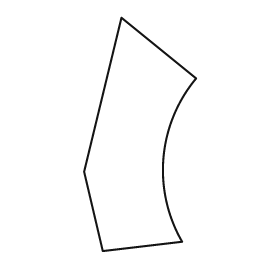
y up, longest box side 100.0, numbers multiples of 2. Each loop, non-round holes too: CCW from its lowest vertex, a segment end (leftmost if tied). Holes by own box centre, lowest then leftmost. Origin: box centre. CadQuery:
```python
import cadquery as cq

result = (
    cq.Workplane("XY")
    .moveTo(-16.0, -50.0)
    .lineTo(18.0, -46.0)
    .threePointArc((10.0, -10.0), (24.0, 24.0))
    .lineTo(-8.0, 50.0)
    .lineTo(-24.0, -16.0)
    .close()
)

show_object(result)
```